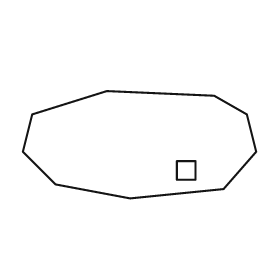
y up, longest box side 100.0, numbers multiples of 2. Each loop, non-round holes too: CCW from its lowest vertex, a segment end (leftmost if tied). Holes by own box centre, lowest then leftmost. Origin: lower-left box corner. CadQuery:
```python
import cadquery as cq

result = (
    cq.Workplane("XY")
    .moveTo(46.0, 0.0)
    .lineTo(86.0, 4.0)
    .lineTo(100.0, 20.0)
    .lineTo(96.0, 36.0)
    .lineTo(82.0, 44.0)
    .lineTo(36.0, 46.0)
    .lineTo(4.0, 36.0)
    .lineTo(0.0, 20.0)
    .lineTo(14.0, 6.0)
    .close()
    .moveTo(66.0, 8.0)
    .lineTo(74.0, 8.0)
    .lineTo(74.0, 16.0)
    .lineTo(66.0, 16.0)
    .close()
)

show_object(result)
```